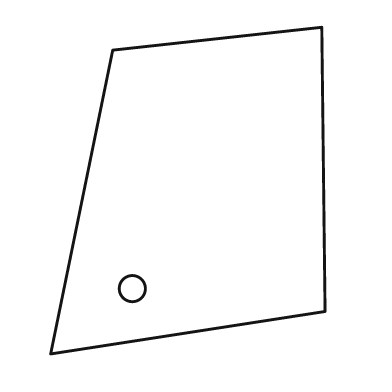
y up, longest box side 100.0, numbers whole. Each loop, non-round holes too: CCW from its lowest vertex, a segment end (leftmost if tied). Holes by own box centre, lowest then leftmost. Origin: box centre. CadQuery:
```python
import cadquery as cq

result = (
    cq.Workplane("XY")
    .moveTo(-42.0, -50.0)
    .lineTo(42.0, -37.0)
    .lineTo(41.0, 50.0)
    .lineTo(-23.0, 43.0)
    .close()
    .moveTo(-17.0, -30.0)
    .circle(4.0)
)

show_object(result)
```